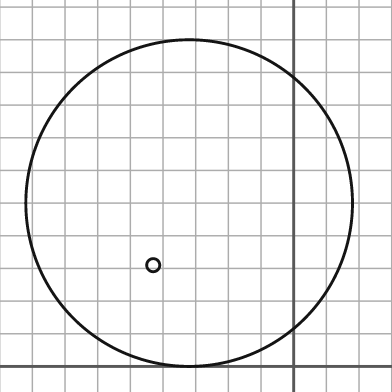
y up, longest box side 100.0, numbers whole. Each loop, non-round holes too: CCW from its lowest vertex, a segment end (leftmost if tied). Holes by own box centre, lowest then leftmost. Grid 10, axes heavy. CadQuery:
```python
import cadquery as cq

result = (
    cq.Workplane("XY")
    .moveTo(-32.0, 50.0)
    .circle(50.0)
    .moveTo(-43.0, 31.0)
    .circle(2.0)
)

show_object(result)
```